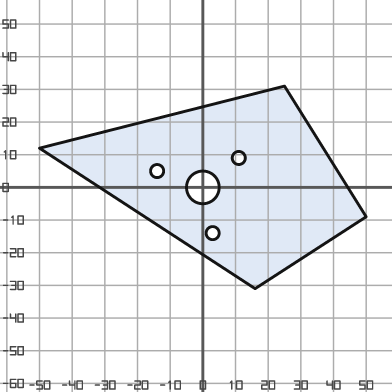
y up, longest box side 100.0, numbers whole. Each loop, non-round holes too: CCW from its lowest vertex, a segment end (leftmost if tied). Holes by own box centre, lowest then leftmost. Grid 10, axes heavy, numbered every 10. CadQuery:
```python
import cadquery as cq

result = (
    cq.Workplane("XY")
    .moveTo(16.0, -31.0)
    .lineTo(50.0, -9.0)
    .lineTo(25.0, 31.0)
    .lineTo(-50.0, 12.0)
    .close()
    .moveTo(3.0, -14.0)
    .circle(2.0)
    .moveTo(0.0, 0.0)
    .circle(5.0)
    .moveTo(-14.0, 5.0)
    .circle(2.0)
    .moveTo(11.0, 9.0)
    .circle(2.0)
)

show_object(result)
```